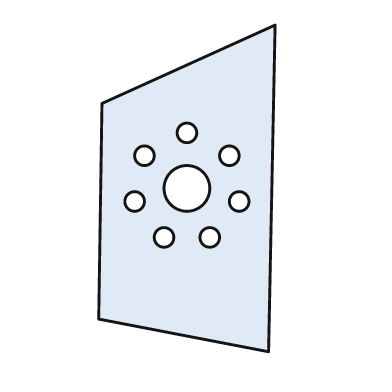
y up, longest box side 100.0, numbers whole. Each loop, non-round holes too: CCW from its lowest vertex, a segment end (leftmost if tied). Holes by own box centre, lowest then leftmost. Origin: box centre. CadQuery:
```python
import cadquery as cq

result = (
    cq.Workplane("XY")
    .moveTo(25.0, -50.0)
    .lineTo(27.0, 50.0)
    .lineTo(-26.0, 26.0)
    .lineTo(-27.0, -40.0)
    .close()
    .moveTo(-7.0, -15.0)
    .circle(3.0)
    .moveTo(7.0, -15.0)
    .circle(3.0)
    .moveTo(-16.0, -4.0)
    .circle(3.0)
    .moveTo(16.0, -4.0)
    .circle(3.0)
    .moveTo(0.0, 0.0)
    .circle(7.0)
    .moveTo(-13.0, 10.0)
    .circle(3.0)
    .moveTo(13.0, 10.0)
    .circle(3.0)
    .moveTo(0.0, 17.0)
    .circle(3.0)
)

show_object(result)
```